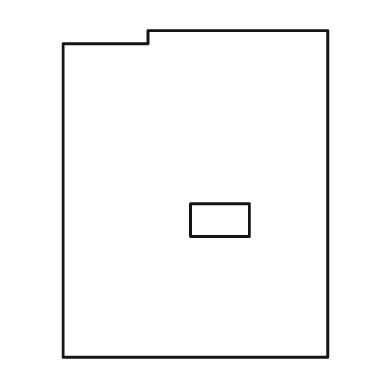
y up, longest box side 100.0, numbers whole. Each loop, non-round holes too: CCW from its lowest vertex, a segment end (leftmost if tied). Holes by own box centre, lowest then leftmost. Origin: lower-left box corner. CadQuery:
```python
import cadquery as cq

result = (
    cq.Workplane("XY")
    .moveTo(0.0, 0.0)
    .lineTo(81.0, 0.0)
    .lineTo(81.0, 100.0)
    .lineTo(26.0, 100.0)
    .lineTo(26.0, 96.0)
    .lineTo(0.0, 96.0)
    .close()
    .moveTo(39.0, 37.0)
    .lineTo(57.0, 37.0)
    .lineTo(57.0, 47.0)
    .lineTo(39.0, 47.0)
    .close()
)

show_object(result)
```